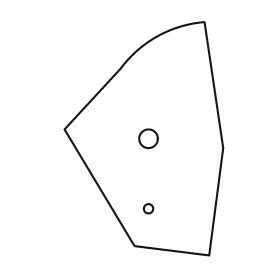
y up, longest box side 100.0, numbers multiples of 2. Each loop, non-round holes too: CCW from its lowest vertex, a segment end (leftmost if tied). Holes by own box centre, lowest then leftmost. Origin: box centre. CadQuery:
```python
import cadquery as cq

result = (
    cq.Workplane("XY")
    .moveTo(28.0, -50.0)
    .lineTo(34.0, -4.0)
    .lineTo(26.0, 50.0)
    .threePointArc((6.0, 44.0), (-10.0, 30.0))
    .lineTo(-34.0, 4.0)
    .lineTo(-4.0, -46.0)
    .close()
    .moveTo(2.0, -30.0)
    .circle(2.0)
    .moveTo(2.0, 0.0)
    .circle(4.0)
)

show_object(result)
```